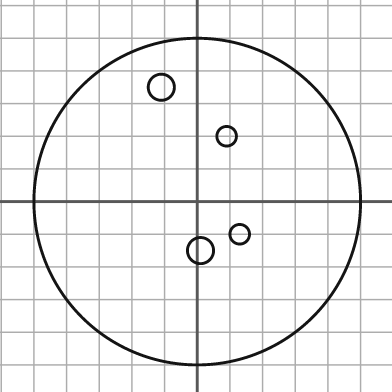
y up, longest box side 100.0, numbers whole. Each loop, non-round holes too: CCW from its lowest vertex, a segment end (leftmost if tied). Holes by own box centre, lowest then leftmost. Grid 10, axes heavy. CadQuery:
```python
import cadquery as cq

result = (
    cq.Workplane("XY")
    .moveTo(0.0, 0.0)
    .circle(50.0)
    .moveTo(1.0, -15.0)
    .circle(4.0)
    .moveTo(13.0, -10.0)
    .circle(3.0)
    .moveTo(9.0, 20.0)
    .circle(3.0)
    .moveTo(-11.0, 35.0)
    .circle(4.0)
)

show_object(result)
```